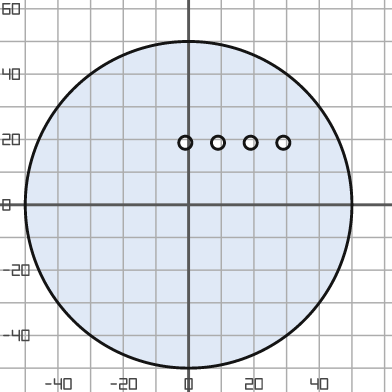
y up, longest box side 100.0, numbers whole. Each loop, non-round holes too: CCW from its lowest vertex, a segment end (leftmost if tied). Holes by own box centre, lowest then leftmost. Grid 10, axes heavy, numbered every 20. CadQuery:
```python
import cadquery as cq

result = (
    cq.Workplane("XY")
    .moveTo(0.0, 0.0)
    .circle(50.0)
    .moveTo(-1.0, 19.0)
    .circle(2.0)
    .moveTo(9.0, 19.0)
    .circle(2.0)
    .moveTo(19.0, 19.0)
    .circle(2.0)
    .moveTo(29.0, 19.0)
    .circle(2.0)
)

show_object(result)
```